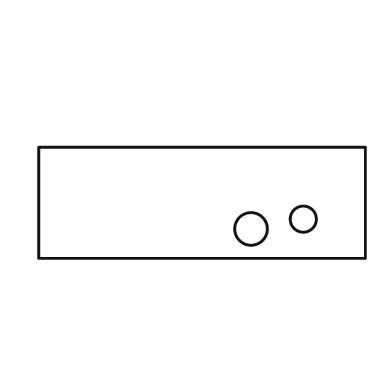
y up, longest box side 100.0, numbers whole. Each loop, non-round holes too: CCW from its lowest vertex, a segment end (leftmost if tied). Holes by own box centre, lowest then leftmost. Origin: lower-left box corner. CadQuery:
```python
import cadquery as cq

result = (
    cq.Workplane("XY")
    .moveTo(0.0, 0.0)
    .lineTo(100.0, 0.0)
    .lineTo(100.0, 34.0)
    .lineTo(0.0, 34.0)
    .close()
    .moveTo(65.0, 9.0)
    .circle(5.0)
    .moveTo(81.0, 12.0)
    .circle(4.0)
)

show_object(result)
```